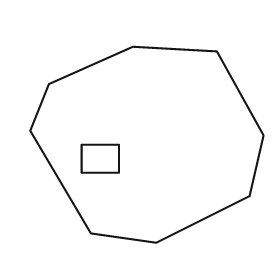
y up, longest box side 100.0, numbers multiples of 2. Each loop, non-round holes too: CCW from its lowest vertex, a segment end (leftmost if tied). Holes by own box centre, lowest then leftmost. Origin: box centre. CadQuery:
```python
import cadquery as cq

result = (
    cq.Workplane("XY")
    .moveTo(4.0, -42.0)
    .lineTo(44.0, -22.0)
    .lineTo(50.0, 4.0)
    .lineTo(30.0, 40.0)
    .lineTo(-6.0, 42.0)
    .lineTo(-42.0, 26.0)
    .lineTo(-50.0, 6.0)
    .lineTo(-24.0, -38.0)
    .close()
    .moveTo(-28.0, -12.0)
    .lineTo(-12.0, -12.0)
    .lineTo(-12.0, 0.0)
    .lineTo(-28.0, 0.0)
    .close()
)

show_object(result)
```